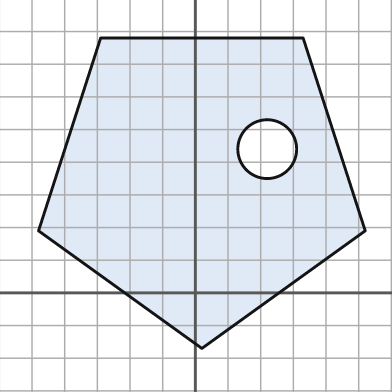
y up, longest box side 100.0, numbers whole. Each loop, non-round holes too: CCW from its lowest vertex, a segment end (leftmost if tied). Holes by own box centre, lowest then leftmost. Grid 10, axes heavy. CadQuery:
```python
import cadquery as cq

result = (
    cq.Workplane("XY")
    .moveTo(2.0, -17.0)
    .lineTo(52.0, 19.0)
    .lineTo(33.0, 78.0)
    .lineTo(-29.0, 78.0)
    .lineTo(-48.0, 19.0)
    .close()
    .moveTo(22.0, 44.0)
    .circle(9.0)
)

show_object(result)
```